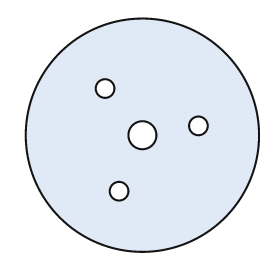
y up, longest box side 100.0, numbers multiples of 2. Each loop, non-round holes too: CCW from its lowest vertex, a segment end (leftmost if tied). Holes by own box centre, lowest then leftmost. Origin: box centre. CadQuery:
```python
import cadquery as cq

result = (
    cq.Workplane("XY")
    .moveTo(0.0, 0.0)
    .circle(50.0)
    .moveTo(-10.0, -24.0)
    .circle(4.0)
    .moveTo(0.0, 0.0)
    .circle(6.0)
    .moveTo(24.0, 4.0)
    .circle(4.0)
    .moveTo(-16.0, 20.0)
    .circle(4.0)
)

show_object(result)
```